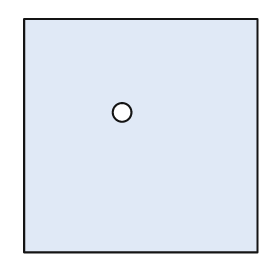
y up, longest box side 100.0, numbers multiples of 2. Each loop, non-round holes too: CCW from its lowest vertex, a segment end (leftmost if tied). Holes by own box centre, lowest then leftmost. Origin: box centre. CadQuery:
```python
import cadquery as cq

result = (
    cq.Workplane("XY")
    .moveTo(-50.0, -50.0)
    .lineTo(50.0, -50.0)
    .lineTo(50.0, 50.0)
    .lineTo(-50.0, 50.0)
    .close()
    .moveTo(-8.0, 10.0)
    .circle(4.0)
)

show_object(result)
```